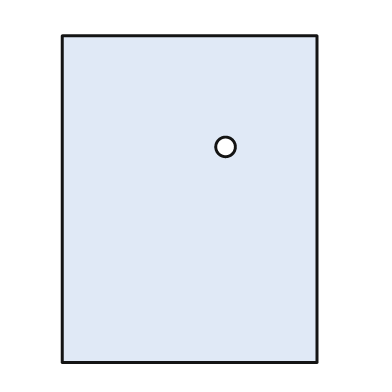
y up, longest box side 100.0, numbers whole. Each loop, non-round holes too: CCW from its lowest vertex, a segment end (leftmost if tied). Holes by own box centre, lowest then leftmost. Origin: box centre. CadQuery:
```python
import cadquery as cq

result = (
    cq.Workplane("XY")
    .moveTo(-39.0, -50.0)
    .lineTo(39.0, -50.0)
    .lineTo(39.0, 50.0)
    .lineTo(-39.0, 50.0)
    .close()
    .moveTo(11.0, 16.0)
    .circle(3.0)
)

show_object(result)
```